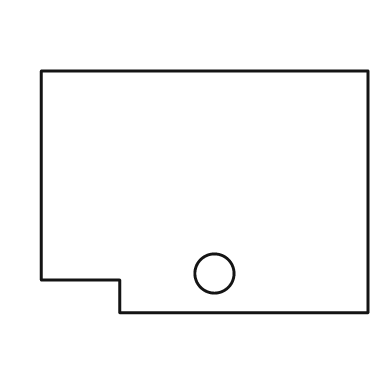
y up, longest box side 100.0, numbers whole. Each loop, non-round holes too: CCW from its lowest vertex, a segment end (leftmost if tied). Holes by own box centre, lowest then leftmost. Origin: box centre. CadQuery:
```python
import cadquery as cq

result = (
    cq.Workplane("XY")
    .moveTo(-26.0, -37.0)
    .lineTo(50.0, -37.0)
    .lineTo(50.0, 37.0)
    .lineTo(-50.0, 37.0)
    .lineTo(-50.0, -27.0)
    .lineTo(-26.0, -27.0)
    .close()
    .moveTo(3.0, -25.0)
    .circle(6.0)
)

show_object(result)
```